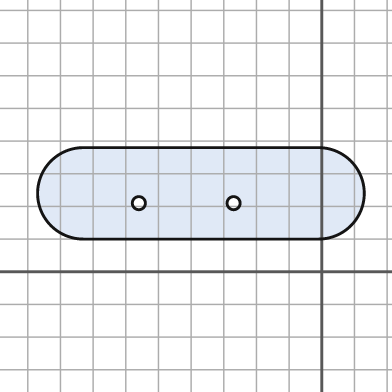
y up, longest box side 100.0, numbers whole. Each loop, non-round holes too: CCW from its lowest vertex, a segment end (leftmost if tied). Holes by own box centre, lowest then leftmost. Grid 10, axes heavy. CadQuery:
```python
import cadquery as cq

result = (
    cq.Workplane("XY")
    .moveTo(-73.0, 10.0)
    .lineTo(-1.0, 10.0)
    .threePointArc((13.0, 24.0), (-1.0, 38.0))
    .lineTo(-73.0, 38.0)
    .threePointArc((-87.0, 24.0), (-73.0, 10.0))
    .close()
    .moveTo(-56.0, 21.0)
    .circle(2.0)
    .moveTo(-27.0, 21.0)
    .circle(2.0)
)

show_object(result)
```